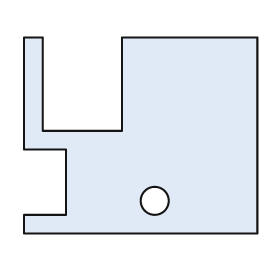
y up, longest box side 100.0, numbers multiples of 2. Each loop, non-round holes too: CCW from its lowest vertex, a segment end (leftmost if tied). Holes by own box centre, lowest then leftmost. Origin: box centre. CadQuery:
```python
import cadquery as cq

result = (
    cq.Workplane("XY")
    .moveTo(-50.0, -42.0)
    .lineTo(50.0, -42.0)
    .lineTo(50.0, 42.0)
    .lineTo(-8.0, 42.0)
    .lineTo(-8.0, 2.0)
    .lineTo(-42.0, 2.0)
    .lineTo(-42.0, 42.0)
    .lineTo(-50.0, 42.0)
    .lineTo(-50.0, -6.0)
    .lineTo(-32.0, -6.0)
    .lineTo(-32.0, -34.0)
    .lineTo(-50.0, -34.0)
    .close()
    .moveTo(6.0, -28.0)
    .circle(6.0)
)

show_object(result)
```